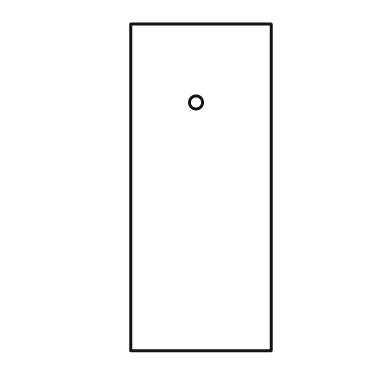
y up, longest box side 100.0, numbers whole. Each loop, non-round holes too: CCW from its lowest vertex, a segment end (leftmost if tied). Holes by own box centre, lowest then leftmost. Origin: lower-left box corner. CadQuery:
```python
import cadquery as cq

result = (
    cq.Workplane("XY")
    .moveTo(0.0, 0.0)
    .lineTo(43.0, 0.0)
    .lineTo(43.0, 100.0)
    .lineTo(0.0, 100.0)
    .close()
    .moveTo(20.0, 76.0)
    .circle(2.0)
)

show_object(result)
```